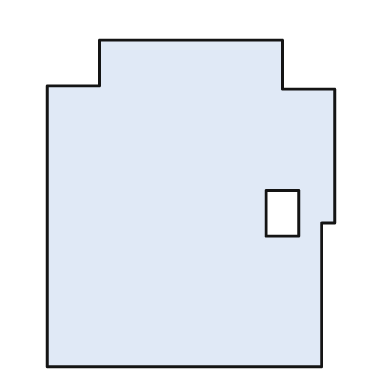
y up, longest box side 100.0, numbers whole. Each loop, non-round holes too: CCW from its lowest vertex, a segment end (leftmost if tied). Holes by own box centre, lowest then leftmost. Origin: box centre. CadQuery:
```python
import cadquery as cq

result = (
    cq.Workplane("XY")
    .moveTo(-44.0, -50.0)
    .lineTo(40.0, -50.0)
    .lineTo(40.0, -6.0)
    .lineTo(44.0, -6.0)
    .lineTo(44.0, 35.0)
    .lineTo(28.0, 35.0)
    .lineTo(28.0, 50.0)
    .lineTo(-28.0, 50.0)
    .lineTo(-28.0, 36.0)
    .lineTo(-44.0, 36.0)
    .close()
    .moveTo(23.0, -10.0)
    .lineTo(33.0, -10.0)
    .lineTo(33.0, 4.0)
    .lineTo(23.0, 4.0)
    .close()
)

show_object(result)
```